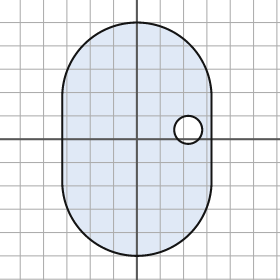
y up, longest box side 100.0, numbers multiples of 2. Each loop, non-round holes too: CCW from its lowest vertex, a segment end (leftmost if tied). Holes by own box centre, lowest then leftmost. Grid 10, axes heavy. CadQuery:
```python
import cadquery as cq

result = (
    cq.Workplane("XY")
    .moveTo(-32.0, -18.0)
    .threePointArc((0.0, -50.0), (32.0, -18.0))
    .lineTo(32.0, 18.0)
    .threePointArc((0.0, 50.0), (-32.0, 18.0))
    .close()
    .moveTo(22.0, 4.0)
    .circle(6.0)
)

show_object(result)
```